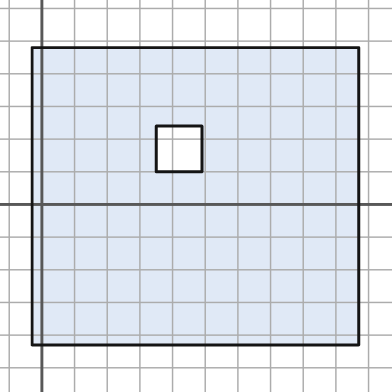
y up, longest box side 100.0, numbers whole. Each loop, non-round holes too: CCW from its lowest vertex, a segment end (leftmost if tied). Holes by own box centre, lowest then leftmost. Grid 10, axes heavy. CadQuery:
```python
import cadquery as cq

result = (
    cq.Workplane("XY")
    .moveTo(-3.0, -43.0)
    .lineTo(97.0, -43.0)
    .lineTo(97.0, 48.0)
    .lineTo(-3.0, 48.0)
    .close()
    .moveTo(35.0, 10.0)
    .lineTo(49.0, 10.0)
    .lineTo(49.0, 24.0)
    .lineTo(35.0, 24.0)
    .close()
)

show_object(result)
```